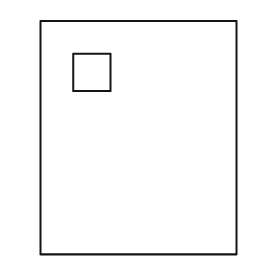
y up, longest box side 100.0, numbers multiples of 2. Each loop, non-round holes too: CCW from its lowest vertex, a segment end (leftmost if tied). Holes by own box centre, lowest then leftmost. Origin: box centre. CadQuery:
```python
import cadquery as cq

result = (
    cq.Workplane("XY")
    .moveTo(-42.0, -50.0)
    .lineTo(42.0, -50.0)
    .lineTo(42.0, 50.0)
    .lineTo(-42.0, 50.0)
    .close()
    .moveTo(-28.0, 20.0)
    .lineTo(-12.0, 20.0)
    .lineTo(-12.0, 36.0)
    .lineTo(-28.0, 36.0)
    .close()
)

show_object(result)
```